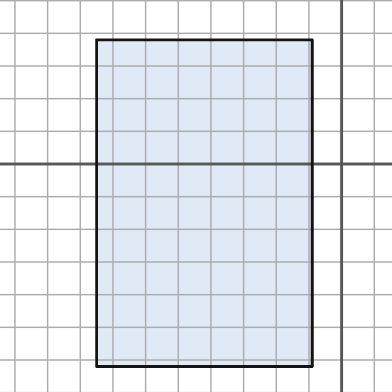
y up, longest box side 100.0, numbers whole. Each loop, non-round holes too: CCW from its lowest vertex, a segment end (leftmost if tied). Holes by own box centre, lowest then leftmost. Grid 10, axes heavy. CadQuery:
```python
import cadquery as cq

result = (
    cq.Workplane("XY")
    .moveTo(-75.0, -62.0)
    .lineTo(-9.0, -62.0)
    .lineTo(-9.0, 38.0)
    .lineTo(-75.0, 38.0)
    .close()
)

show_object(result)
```